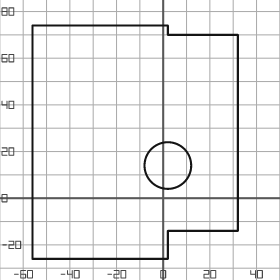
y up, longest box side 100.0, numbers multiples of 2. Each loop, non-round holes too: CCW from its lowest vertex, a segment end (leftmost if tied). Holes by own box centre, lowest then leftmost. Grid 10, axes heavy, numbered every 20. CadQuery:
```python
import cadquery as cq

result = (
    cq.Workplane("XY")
    .moveTo(-56.0, -26.0)
    .lineTo(2.0, -26.0)
    .lineTo(2.0, -14.0)
    .lineTo(32.0, -14.0)
    .lineTo(32.0, 70.0)
    .lineTo(2.0, 70.0)
    .lineTo(2.0, 74.0)
    .lineTo(-56.0, 74.0)
    .close()
    .moveTo(2.0, 14.0)
    .circle(10.0)
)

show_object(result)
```